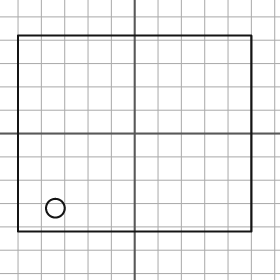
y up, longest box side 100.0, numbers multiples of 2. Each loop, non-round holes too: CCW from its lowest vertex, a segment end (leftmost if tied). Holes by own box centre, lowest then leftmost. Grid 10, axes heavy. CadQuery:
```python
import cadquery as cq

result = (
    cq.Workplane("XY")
    .moveTo(-50.0, -42.0)
    .lineTo(50.0, -42.0)
    .lineTo(50.0, 42.0)
    .lineTo(-50.0, 42.0)
    .close()
    .moveTo(-34.0, -32.0)
    .circle(4.0)
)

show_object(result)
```